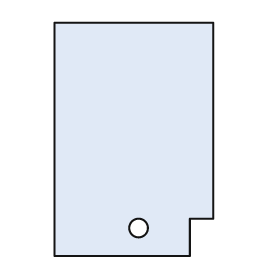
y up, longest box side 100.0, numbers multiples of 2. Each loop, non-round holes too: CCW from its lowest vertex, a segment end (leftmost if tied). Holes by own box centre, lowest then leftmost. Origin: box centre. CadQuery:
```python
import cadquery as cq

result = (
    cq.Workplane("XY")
    .moveTo(-34.0, -50.0)
    .lineTo(24.0, -50.0)
    .lineTo(24.0, -34.0)
    .lineTo(34.0, -34.0)
    .lineTo(34.0, 50.0)
    .lineTo(-34.0, 50.0)
    .close()
    .moveTo(2.0, -38.0)
    .circle(4.0)
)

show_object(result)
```